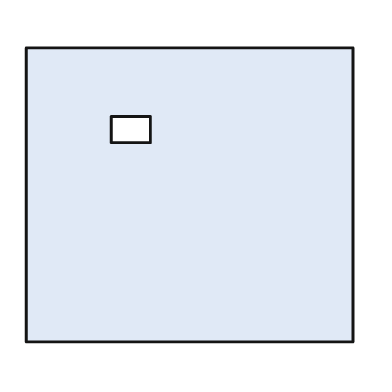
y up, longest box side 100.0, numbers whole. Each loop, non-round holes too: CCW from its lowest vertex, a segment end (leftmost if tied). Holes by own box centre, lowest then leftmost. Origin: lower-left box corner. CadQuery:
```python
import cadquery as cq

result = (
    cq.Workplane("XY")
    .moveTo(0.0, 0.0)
    .lineTo(100.0, 0.0)
    .lineTo(100.0, 90.0)
    .lineTo(0.0, 90.0)
    .close()
    .moveTo(26.0, 61.0)
    .lineTo(38.0, 61.0)
    .lineTo(38.0, 69.0)
    .lineTo(26.0, 69.0)
    .close()
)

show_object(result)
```